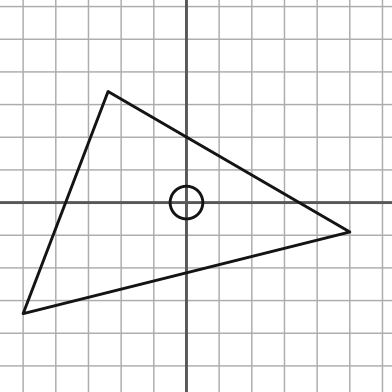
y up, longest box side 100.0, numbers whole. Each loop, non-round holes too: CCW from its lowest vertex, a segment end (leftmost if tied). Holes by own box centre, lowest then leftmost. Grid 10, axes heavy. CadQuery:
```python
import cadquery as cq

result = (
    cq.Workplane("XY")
    .moveTo(-50.0, -34.0)
    .lineTo(50.0, -9.0)
    .lineTo(-24.0, 34.0)
    .close()
    .moveTo(0.0, 0.0)
    .circle(5.0)
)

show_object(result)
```